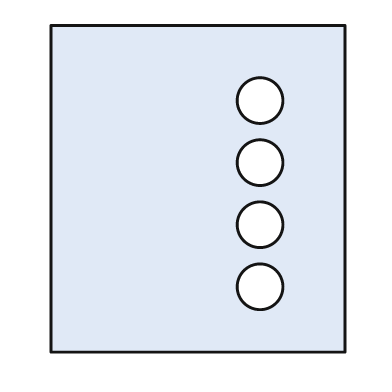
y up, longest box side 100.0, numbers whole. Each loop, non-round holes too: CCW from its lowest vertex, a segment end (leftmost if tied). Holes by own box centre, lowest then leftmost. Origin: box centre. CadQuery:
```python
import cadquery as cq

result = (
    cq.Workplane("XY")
    .moveTo(-45.0, -50.0)
    .lineTo(45.0, -50.0)
    .lineTo(45.0, 50.0)
    .lineTo(-45.0, 50.0)
    .close()
    .moveTo(19.0, -30.0)
    .circle(7.0)
    .moveTo(19.0, -11.0)
    .circle(7.0)
    .moveTo(19.0, 8.0)
    .circle(7.0)
    .moveTo(19.0, 27.0)
    .circle(7.0)
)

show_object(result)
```